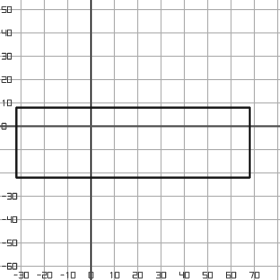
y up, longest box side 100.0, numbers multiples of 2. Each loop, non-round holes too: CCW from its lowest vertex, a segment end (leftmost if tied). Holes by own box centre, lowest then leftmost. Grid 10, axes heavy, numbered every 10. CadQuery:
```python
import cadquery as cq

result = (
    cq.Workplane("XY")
    .moveTo(-32.0, -22.0)
    .lineTo(68.0, -22.0)
    .lineTo(68.0, 8.0)
    .lineTo(-32.0, 8.0)
    .close()
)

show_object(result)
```